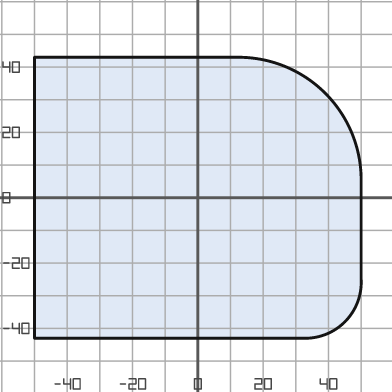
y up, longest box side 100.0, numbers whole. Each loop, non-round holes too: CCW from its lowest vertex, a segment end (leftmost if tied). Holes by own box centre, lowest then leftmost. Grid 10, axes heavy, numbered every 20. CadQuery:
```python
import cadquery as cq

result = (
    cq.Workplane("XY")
    .moveTo(-50.0, -43.0)
    .lineTo(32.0, -43.0)
    .threePointArc((45.0, -38.0), (50.0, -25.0))
    .lineTo(50.0, 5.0)
    .threePointArc((39.0, 32.0), (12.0, 43.0))
    .lineTo(-50.0, 43.0)
    .close()
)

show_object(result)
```